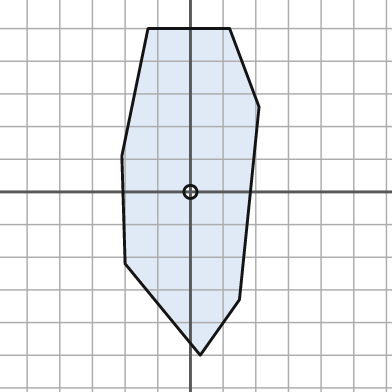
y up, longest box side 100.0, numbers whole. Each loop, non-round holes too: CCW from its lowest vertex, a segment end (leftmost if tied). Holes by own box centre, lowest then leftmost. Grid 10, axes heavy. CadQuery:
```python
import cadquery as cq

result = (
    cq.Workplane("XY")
    .moveTo(3.0, -50.0)
    .lineTo(15.0, -33.0)
    .lineTo(21.0, 26.0)
    .lineTo(12.0, 50.0)
    .lineTo(-13.0, 50.0)
    .lineTo(-21.0, 11.0)
    .lineTo(-20.0, -22.0)
    .close()
    .moveTo(0.0, 0.0)
    .circle(2.0)
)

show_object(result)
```